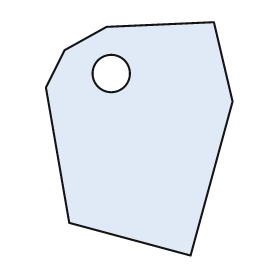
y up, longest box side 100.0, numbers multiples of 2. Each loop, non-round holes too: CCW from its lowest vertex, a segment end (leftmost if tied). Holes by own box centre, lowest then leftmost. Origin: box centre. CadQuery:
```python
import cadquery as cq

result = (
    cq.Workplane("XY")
    .moveTo(22.0, -50.0)
    .lineTo(40.0, 16.0)
    .lineTo(32.0, 50.0)
    .lineTo(-14.0, 48.0)
    .lineTo(-32.0, 38.0)
    .lineTo(-40.0, 22.0)
    .lineTo(-30.0, -36.0)
    .close()
    .moveTo(-12.0, 28.0)
    .circle(8.0)
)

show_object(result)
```